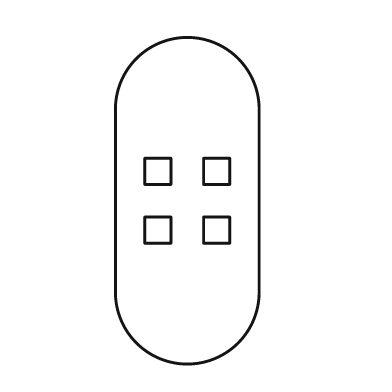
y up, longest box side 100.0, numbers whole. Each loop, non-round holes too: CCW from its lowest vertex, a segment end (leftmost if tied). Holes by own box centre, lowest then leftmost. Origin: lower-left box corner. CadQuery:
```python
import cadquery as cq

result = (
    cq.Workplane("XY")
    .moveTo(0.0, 22.0)
    .threePointArc((22.0, 0.0), (44.0, 22.0))
    .lineTo(44.0, 78.0)
    .threePointArc((22.0, 100.0), (0.0, 78.0))
    .close()
    .moveTo(9.0, 37.0)
    .lineTo(17.0, 37.0)
    .lineTo(17.0, 45.0)
    .lineTo(9.0, 45.0)
    .close()
    .moveTo(27.0, 37.0)
    .lineTo(35.0, 37.0)
    .lineTo(35.0, 45.0)
    .lineTo(27.0, 45.0)
    .close()
    .moveTo(9.0, 55.0)
    .lineTo(17.0, 55.0)
    .lineTo(17.0, 63.0)
    .lineTo(9.0, 63.0)
    .close()
    .moveTo(27.0, 55.0)
    .lineTo(35.0, 55.0)
    .lineTo(35.0, 63.0)
    .lineTo(27.0, 63.0)
    .close()
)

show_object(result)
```